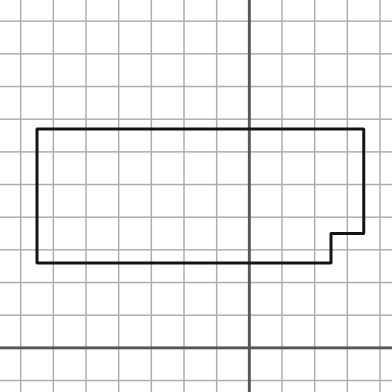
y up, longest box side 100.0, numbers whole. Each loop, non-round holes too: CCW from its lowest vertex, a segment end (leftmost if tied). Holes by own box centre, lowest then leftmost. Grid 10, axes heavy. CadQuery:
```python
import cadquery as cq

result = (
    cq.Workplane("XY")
    .moveTo(-65.0, 26.0)
    .lineTo(25.0, 26.0)
    .lineTo(25.0, 35.0)
    .lineTo(35.0, 35.0)
    .lineTo(35.0, 67.0)
    .lineTo(-65.0, 67.0)
    .close()
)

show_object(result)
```